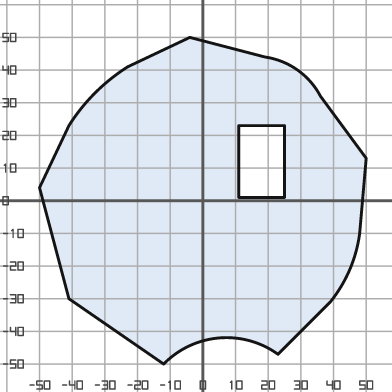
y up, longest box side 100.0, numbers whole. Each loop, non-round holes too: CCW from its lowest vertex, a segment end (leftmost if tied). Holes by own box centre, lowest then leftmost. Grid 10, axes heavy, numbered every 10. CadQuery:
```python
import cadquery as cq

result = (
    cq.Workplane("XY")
    .moveTo(-12.0, -50.0)
    .threePointArc((5.0, -42.0), (23.0, -47.0))
    .lineTo(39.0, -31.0)
    .threePointArc((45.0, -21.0), (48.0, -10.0))
    .lineTo(50.0, 13.0)
    .lineTo(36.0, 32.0)
    .threePointArc((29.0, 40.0), (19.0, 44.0))
    .lineTo(-4.0, 50.0)
    .lineTo(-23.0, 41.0)
    .threePointArc((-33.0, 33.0), (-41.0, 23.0))
    .lineTo(-50.0, 4.0)
    .lineTo(-41.0, -30.0)
    .close()
    .moveTo(11.0, 1.0)
    .lineTo(25.0, 1.0)
    .lineTo(25.0, 23.0)
    .lineTo(11.0, 23.0)
    .close()
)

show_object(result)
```